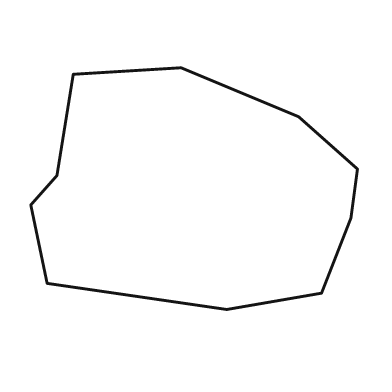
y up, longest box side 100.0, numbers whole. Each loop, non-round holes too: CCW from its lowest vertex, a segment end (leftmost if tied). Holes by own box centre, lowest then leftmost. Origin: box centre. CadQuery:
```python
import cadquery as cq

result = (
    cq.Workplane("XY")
    .moveTo(10.0, -37.0)
    .lineTo(39.0, -32.0)
    .lineTo(48.0, -9.0)
    .lineTo(50.0, 6.0)
    .lineTo(32.0, 22.0)
    .lineTo(-4.0, 37.0)
    .lineTo(-37.0, 35.0)
    .lineTo(-42.0, 4.0)
    .lineTo(-50.0, -5.0)
    .lineTo(-45.0, -29.0)
    .close()
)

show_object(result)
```